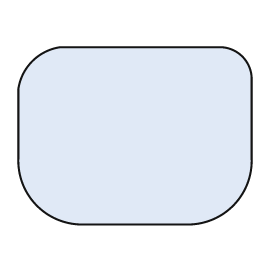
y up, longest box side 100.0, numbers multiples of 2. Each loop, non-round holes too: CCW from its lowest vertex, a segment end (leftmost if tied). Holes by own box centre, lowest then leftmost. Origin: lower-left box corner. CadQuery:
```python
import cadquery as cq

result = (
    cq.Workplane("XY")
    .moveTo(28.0, 0.0)
    .lineTo(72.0, 0.0)
    .threePointArc((92.0, 8.0), (100.0, 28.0))
    .lineTo(100.0, 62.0)
    .threePointArc((96.0, 72.0), (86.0, 76.0))
    .lineTo(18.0, 76.0)
    .threePointArc((6.0, 70.0), (0.0, 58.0))
    .lineTo(0.0, 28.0)
    .threePointArc((8.0, 8.0), (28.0, 0.0))
    .close()
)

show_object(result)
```